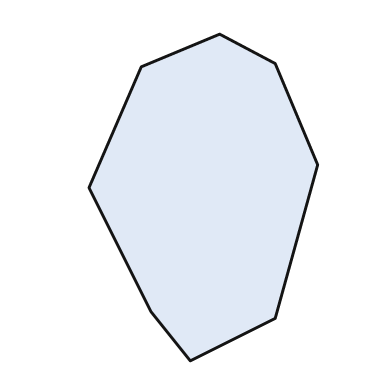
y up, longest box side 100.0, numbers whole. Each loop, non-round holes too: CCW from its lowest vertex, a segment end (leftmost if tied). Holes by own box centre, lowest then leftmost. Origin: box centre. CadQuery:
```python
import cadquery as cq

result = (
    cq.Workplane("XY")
    .moveTo(-4.0, -50.0)
    .lineTo(22.0, -37.0)
    .lineTo(35.0, 10.0)
    .lineTo(22.0, 41.0)
    .lineTo(5.0, 50.0)
    .lineTo(-19.0, 40.0)
    .lineTo(-35.0, 3.0)
    .lineTo(-16.0, -35.0)
    .close()
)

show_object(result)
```